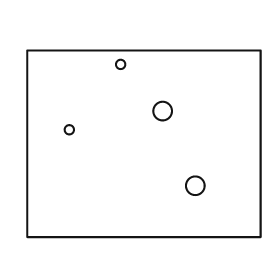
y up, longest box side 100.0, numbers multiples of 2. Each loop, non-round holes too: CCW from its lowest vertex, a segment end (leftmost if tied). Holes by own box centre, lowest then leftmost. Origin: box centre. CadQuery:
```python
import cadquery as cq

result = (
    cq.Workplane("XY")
    .moveTo(-50.0, -40.0)
    .lineTo(50.0, -40.0)
    .lineTo(50.0, 40.0)
    .lineTo(-50.0, 40.0)
    .close()
    .moveTo(22.0, -18.0)
    .circle(4.0)
    .moveTo(-32.0, 6.0)
    .circle(2.0)
    .moveTo(8.0, 14.0)
    .circle(4.0)
    .moveTo(-10.0, 34.0)
    .circle(2.0)
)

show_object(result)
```